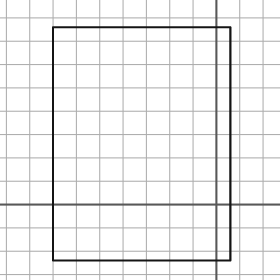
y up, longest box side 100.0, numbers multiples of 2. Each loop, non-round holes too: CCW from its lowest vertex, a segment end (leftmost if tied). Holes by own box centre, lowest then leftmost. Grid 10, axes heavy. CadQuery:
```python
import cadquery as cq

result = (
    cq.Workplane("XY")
    .moveTo(-70.0, -24.0)
    .lineTo(6.0, -24.0)
    .lineTo(6.0, 76.0)
    .lineTo(-70.0, 76.0)
    .close()
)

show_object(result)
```